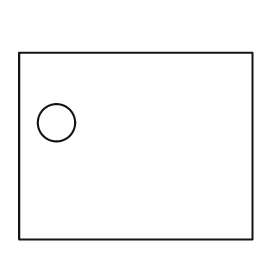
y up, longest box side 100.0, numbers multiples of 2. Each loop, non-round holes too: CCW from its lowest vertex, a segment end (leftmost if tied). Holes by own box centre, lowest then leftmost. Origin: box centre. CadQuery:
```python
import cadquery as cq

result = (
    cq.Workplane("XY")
    .moveTo(-50.0, -40.0)
    .lineTo(50.0, -40.0)
    .lineTo(50.0, 40.0)
    .lineTo(-50.0, 40.0)
    .close()
    .moveTo(-34.0, 10.0)
    .circle(8.0)
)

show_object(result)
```